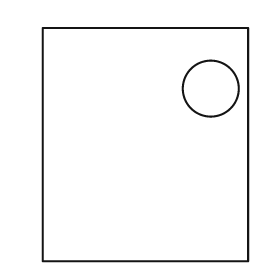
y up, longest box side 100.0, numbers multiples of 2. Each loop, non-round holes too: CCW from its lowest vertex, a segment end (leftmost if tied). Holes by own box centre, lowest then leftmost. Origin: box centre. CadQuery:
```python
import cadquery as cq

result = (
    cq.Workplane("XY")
    .moveTo(-44.0, -50.0)
    .lineTo(44.0, -50.0)
    .lineTo(44.0, 50.0)
    .lineTo(-44.0, 50.0)
    .close()
    .moveTo(28.0, 24.0)
    .circle(12.0)
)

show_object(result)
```